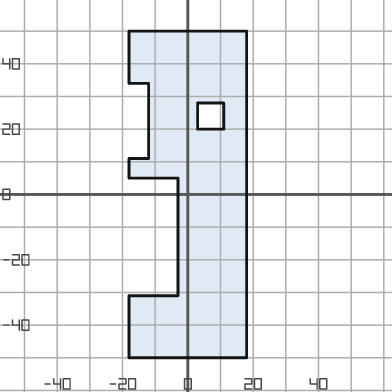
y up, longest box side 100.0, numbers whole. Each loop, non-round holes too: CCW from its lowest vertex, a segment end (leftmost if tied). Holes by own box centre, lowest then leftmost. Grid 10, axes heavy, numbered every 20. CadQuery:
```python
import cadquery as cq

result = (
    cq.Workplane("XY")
    .moveTo(-18.0, -50.0)
    .lineTo(18.0, -50.0)
    .lineTo(18.0, 50.0)
    .lineTo(-18.0, 50.0)
    .lineTo(-18.0, 34.0)
    .lineTo(-12.0, 34.0)
    .lineTo(-12.0, 11.0)
    .lineTo(-18.0, 11.0)
    .lineTo(-18.0, 5.0)
    .lineTo(-3.0, 5.0)
    .lineTo(-3.0, -31.0)
    .lineTo(-18.0, -31.0)
    .close()
    .moveTo(3.0, 20.0)
    .lineTo(11.0, 20.0)
    .lineTo(11.0, 28.0)
    .lineTo(3.0, 28.0)
    .close()
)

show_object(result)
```